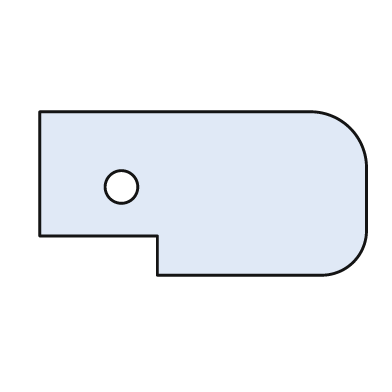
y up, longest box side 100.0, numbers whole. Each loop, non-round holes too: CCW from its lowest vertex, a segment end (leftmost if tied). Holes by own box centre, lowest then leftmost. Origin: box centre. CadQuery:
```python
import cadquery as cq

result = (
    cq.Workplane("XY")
    .moveTo(-14.0, -25.0)
    .lineTo(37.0, -25.0)
    .threePointArc((46.0, -21.0), (50.0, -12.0))
    .lineTo(50.0, 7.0)
    .threePointArc((45.0, 20.0), (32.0, 25.0))
    .lineTo(-50.0, 25.0)
    .lineTo(-50.0, -13.0)
    .lineTo(-14.0, -13.0)
    .close()
    .moveTo(-25.0, 2.0)
    .circle(5.0)
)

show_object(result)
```